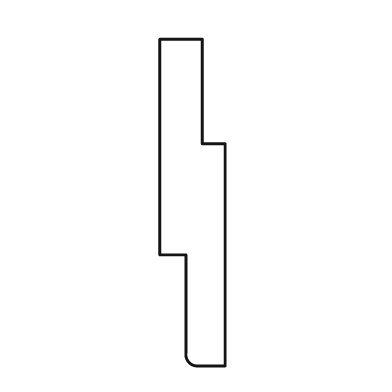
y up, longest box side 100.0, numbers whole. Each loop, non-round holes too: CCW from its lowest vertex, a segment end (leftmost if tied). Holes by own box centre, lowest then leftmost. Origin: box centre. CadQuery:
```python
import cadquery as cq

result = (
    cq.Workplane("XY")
    .moveTo(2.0, -50.0)
    .lineTo(10.0, -50.0)
    .lineTo(10.0, 18.0)
    .lineTo(3.0, 18.0)
    .lineTo(3.0, 50.0)
    .lineTo(-10.0, 50.0)
    .lineTo(-10.0, -16.0)
    .lineTo(-2.0, -16.0)
    .lineTo(-2.0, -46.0)
    .threePointArc((-1.0, -49.0), (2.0, -50.0))
    .close()
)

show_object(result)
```